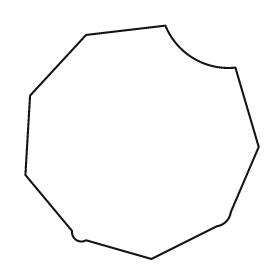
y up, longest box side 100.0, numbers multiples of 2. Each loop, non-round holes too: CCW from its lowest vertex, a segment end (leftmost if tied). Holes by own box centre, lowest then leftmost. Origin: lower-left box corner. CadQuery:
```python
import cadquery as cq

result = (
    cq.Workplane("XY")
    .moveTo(54.0, 0.0)
    .lineTo(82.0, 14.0)
    .threePointArc((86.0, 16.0), (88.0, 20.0))
    .lineTo(100.0, 48.0)
    .lineTo(90.0, 82.0)
    .threePointArc((72.0, 86.0), (60.0, 100.0))
    .lineTo(26.0, 96.0)
    .lineTo(2.0, 70.0)
    .lineTo(0.0, 36.0)
    .lineTo(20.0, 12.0)
    .threePointArc((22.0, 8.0), (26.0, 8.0))
    .close()
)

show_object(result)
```